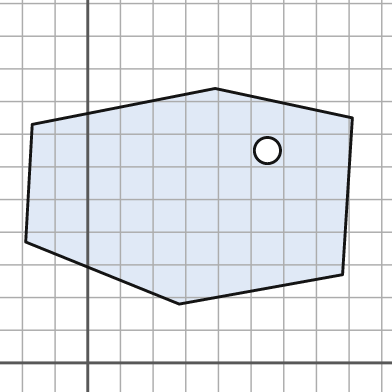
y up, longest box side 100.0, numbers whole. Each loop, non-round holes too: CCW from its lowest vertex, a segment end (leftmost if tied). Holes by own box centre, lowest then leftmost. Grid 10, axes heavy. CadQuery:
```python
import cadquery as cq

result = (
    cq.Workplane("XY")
    .moveTo(28.0, 18.0)
    .lineTo(78.0, 27.0)
    .lineTo(81.0, 75.0)
    .lineTo(39.0, 84.0)
    .lineTo(-17.0, 73.0)
    .lineTo(-19.0, 37.0)
    .close()
    .moveTo(55.0, 65.0)
    .circle(4.0)
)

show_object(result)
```